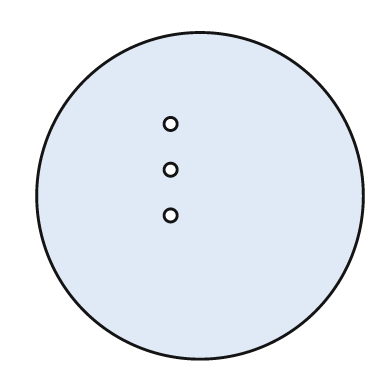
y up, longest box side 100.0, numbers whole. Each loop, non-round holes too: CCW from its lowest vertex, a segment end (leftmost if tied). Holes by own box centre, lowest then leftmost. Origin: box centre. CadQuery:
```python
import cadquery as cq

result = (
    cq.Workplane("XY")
    .moveTo(0.0, 0.0)
    .circle(50.0)
    .moveTo(-9.0, -6.0)
    .circle(2.0)
    .moveTo(-9.0, 8.0)
    .circle(2.0)
    .moveTo(-9.0, 22.0)
    .circle(2.0)
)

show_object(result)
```